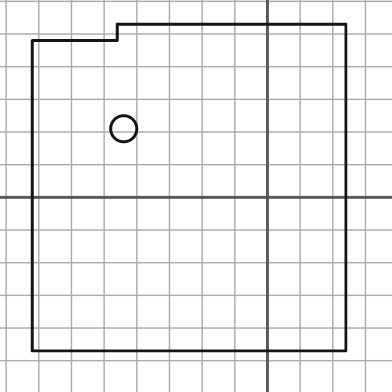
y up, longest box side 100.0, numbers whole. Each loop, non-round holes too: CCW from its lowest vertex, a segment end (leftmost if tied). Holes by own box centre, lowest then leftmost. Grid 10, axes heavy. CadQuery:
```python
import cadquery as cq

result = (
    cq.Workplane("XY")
    .moveTo(-72.0, -47.0)
    .lineTo(24.0, -47.0)
    .lineTo(24.0, 53.0)
    .lineTo(-46.0, 53.0)
    .lineTo(-46.0, 48.0)
    .lineTo(-72.0, 48.0)
    .close()
    .moveTo(-44.0, 21.0)
    .circle(4.0)
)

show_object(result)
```